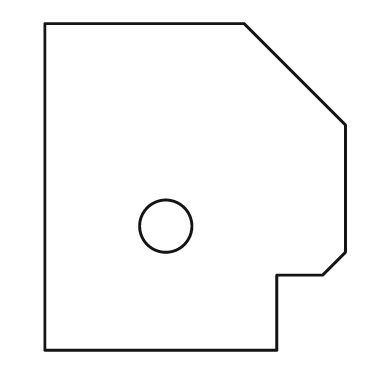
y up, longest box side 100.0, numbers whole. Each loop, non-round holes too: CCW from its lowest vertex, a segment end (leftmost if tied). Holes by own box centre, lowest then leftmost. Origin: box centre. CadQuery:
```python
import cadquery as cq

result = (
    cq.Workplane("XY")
    .moveTo(-46.0, -50.0)
    .lineTo(25.0, -50.0)
    .lineTo(25.0, -27.0)
    .lineTo(39.0, -27.0)
    .lineTo(46.0, -20.0)
    .lineTo(46.0, 19.0)
    .lineTo(15.0, 50.0)
    .lineTo(-46.0, 50.0)
    .close()
    .moveTo(-9.0, -12.0)
    .circle(8.0)
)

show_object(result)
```